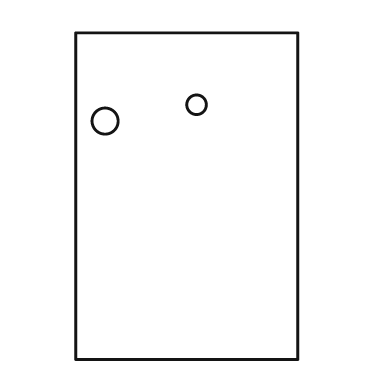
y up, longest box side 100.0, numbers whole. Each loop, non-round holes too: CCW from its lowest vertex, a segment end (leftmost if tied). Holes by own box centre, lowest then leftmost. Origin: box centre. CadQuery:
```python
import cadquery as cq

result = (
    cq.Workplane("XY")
    .moveTo(-34.0, -50.0)
    .lineTo(34.0, -50.0)
    .lineTo(34.0, 50.0)
    .lineTo(-34.0, 50.0)
    .close()
    .moveTo(-25.0, 23.0)
    .circle(4.0)
    .moveTo(3.0, 28.0)
    .circle(3.0)
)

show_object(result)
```